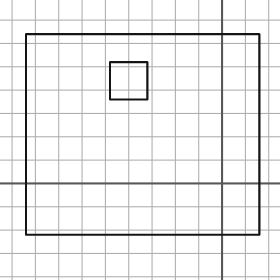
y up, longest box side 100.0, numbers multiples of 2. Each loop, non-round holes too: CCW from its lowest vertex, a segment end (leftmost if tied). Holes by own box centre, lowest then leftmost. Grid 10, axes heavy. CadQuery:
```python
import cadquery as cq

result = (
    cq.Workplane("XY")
    .moveTo(-84.0, -22.0)
    .lineTo(16.0, -22.0)
    .lineTo(16.0, 64.0)
    .lineTo(-84.0, 64.0)
    .close()
    .moveTo(-48.0, 36.0)
    .lineTo(-32.0, 36.0)
    .lineTo(-32.0, 52.0)
    .lineTo(-48.0, 52.0)
    .close()
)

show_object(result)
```